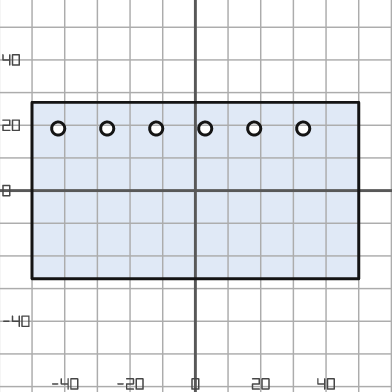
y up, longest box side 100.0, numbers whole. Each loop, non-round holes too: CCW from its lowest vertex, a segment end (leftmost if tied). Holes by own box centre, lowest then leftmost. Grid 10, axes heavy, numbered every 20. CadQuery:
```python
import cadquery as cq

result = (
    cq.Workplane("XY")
    .moveTo(-50.0, -27.0)
    .lineTo(50.0, -27.0)
    .lineTo(50.0, 27.0)
    .lineTo(-50.0, 27.0)
    .close()
    .moveTo(-42.0, 19.0)
    .circle(2.0)
    .moveTo(-27.0, 19.0)
    .circle(2.0)
    .moveTo(-12.0, 19.0)
    .circle(2.0)
    .moveTo(3.0, 19.0)
    .circle(2.0)
    .moveTo(18.0, 19.0)
    .circle(2.0)
    .moveTo(33.0, 19.0)
    .circle(2.0)
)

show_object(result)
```